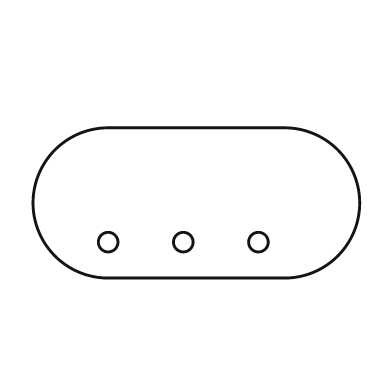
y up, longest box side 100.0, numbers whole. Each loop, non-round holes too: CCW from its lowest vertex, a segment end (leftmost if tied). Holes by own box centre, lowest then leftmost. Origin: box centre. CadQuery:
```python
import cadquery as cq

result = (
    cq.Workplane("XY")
    .moveTo(-27.0, -23.0)
    .lineTo(27.0, -23.0)
    .threePointArc((50.0, 0.0), (27.0, 23.0))
    .lineTo(-27.0, 23.0)
    .threePointArc((-50.0, 0.0), (-27.0, -23.0))
    .close()
    .moveTo(-27.0, -12.0)
    .circle(3.0)
    .moveTo(-4.0, -12.0)
    .circle(3.0)
    .moveTo(19.0, -12.0)
    .circle(3.0)
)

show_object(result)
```